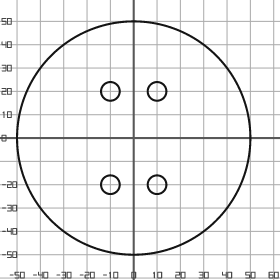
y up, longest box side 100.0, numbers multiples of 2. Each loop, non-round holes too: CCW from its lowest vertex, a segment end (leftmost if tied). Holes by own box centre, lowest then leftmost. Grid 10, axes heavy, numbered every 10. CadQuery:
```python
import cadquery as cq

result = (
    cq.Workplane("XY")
    .moveTo(0.0, 0.0)
    .circle(50.0)
    .moveTo(-10.0, -20.0)
    .circle(4.0)
    .moveTo(10.0, -20.0)
    .circle(4.0)
    .moveTo(-10.0, 20.0)
    .circle(4.0)
    .moveTo(10.0, 20.0)
    .circle(4.0)
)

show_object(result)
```